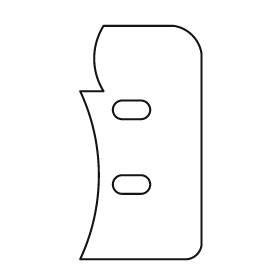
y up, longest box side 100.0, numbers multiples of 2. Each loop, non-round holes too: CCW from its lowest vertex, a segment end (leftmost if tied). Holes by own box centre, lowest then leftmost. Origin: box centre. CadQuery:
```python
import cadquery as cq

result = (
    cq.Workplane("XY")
    .moveTo(-26.0, -50.0)
    .lineTo(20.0, -50.0)
    .threePointArc((24.0, -48.0), (26.0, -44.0))
    .lineTo(26.0, 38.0)
    .threePointArc((22.0, 46.0), (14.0, 50.0))
    .lineTo(-16.0, 50.0)
    .threePointArc((-20.0, 36.0), (-16.0, 22.0))
    .lineTo(-26.0, 22.0)
    .threePointArc((-18.0, -14.0), (-26.0, -50.0))
    .close()
    .moveTo(-8.0, -22.0)
    .lineTo(0.0, -22.0)
    .threePointArc((4.0, -18.0), (0.0, -14.0))
    .lineTo(-8.0, -14.0)
    .threePointArc((-12.0, -18.0), (-8.0, -22.0))
    .close()
    .moveTo(-8.0, 10.0)
    .lineTo(0.0, 10.0)
    .threePointArc((4.0, 14.0), (0.0, 18.0))
    .lineTo(-8.0, 18.0)
    .threePointArc((-12.0, 14.0), (-8.0, 10.0))
    .close()
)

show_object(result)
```